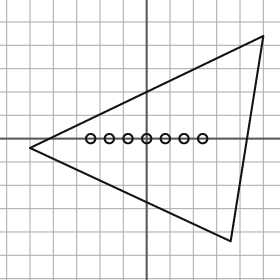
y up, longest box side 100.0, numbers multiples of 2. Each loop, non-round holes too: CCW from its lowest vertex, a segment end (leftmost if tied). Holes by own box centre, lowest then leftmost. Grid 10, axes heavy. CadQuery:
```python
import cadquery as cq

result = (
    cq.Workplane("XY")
    .moveTo(36.0, -44.0)
    .lineTo(50.0, 44.0)
    .lineTo(-50.0, -4.0)
    .close()
    .moveTo(-24.0, 0.0)
    .circle(2.0)
    .moveTo(-16.0, 0.0)
    .circle(2.0)
    .moveTo(-8.0, 0.0)
    .circle(2.0)
    .moveTo(0.0, 0.0)
    .circle(2.0)
    .moveTo(8.0, 0.0)
    .circle(2.0)
    .moveTo(16.0, 0.0)
    .circle(2.0)
    .moveTo(24.0, 0.0)
    .circle(2.0)
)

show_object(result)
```